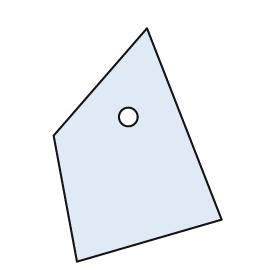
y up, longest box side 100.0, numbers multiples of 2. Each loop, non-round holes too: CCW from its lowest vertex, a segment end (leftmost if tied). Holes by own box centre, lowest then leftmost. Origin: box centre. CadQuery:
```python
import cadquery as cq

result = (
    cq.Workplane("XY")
    .moveTo(-26.0, -50.0)
    .lineTo(36.0, -32.0)
    .lineTo(4.0, 50.0)
    .lineTo(-36.0, 4.0)
    .close()
    .moveTo(-4.0, 12.0)
    .circle(4.0)
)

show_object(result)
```